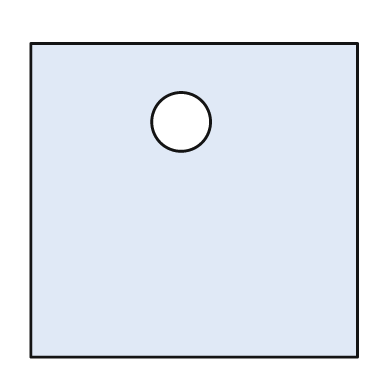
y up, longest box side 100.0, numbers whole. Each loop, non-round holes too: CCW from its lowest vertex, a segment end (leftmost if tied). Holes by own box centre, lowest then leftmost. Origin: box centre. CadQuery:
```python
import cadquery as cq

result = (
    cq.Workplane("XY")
    .moveTo(-50.0, -48.0)
    .lineTo(50.0, -48.0)
    .lineTo(50.0, 48.0)
    .lineTo(-50.0, 48.0)
    .close()
    .moveTo(-4.0, 24.0)
    .circle(9.0)
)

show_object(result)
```